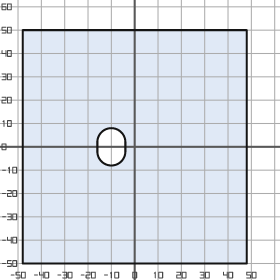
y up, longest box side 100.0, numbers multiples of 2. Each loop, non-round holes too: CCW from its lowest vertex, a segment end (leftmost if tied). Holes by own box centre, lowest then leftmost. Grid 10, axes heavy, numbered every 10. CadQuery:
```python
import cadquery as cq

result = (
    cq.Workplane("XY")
    .moveTo(-48.0, -50.0)
    .lineTo(48.0, -50.0)
    .lineTo(48.0, 50.0)
    .lineTo(-48.0, 50.0)
    .close()
    .moveTo(-16.0, -2.0)
    .threePointArc((-10.0, -8.0), (-4.0, -2.0))
    .lineTo(-4.0, 2.0)
    .threePointArc((-10.0, 8.0), (-16.0, 2.0))
    .close()
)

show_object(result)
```